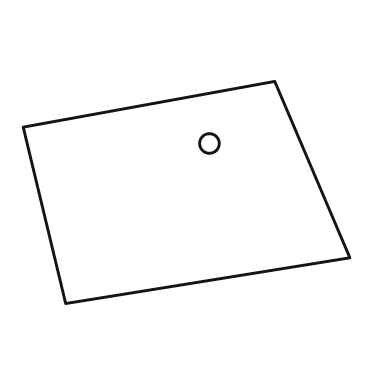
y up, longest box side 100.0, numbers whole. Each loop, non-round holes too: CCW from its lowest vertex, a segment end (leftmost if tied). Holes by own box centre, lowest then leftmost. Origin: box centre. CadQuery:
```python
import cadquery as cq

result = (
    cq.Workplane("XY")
    .moveTo(-37.0, -34.0)
    .lineTo(50.0, -20.0)
    .lineTo(27.0, 34.0)
    .lineTo(-50.0, 20.0)
    .close()
    .moveTo(7.0, 15.0)
    .circle(3.0)
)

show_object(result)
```